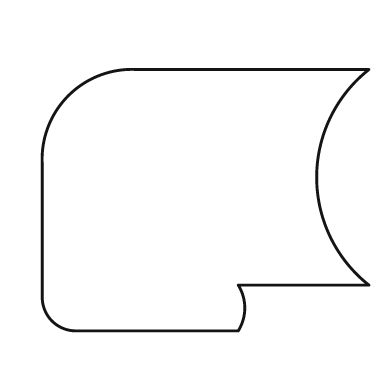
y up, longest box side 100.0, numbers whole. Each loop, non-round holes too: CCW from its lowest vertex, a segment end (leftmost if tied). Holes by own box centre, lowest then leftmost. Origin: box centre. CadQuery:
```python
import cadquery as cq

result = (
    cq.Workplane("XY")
    .moveTo(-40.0, -40.0)
    .lineTo(10.0, -40.0)
    .threePointArc((12.0, -33.0), (10.0, -26.0))
    .lineTo(50.0, -26.0)
    .threePointArc((34.0, 7.0), (50.0, 40.0))
    .lineTo(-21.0, 40.0)
    .threePointArc((-42.0, 32.0), (-50.0, 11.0))
    .lineTo(-50.0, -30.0)
    .threePointArc((-47.0, -37.0), (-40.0, -40.0))
    .close()
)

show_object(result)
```